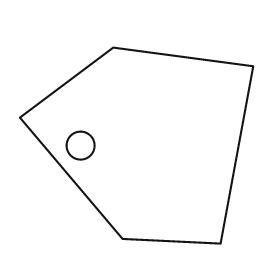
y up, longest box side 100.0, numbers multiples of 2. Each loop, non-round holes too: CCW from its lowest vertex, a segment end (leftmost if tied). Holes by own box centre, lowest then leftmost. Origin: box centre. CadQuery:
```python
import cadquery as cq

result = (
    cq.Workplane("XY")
    .moveTo(36.0, -42.0)
    .lineTo(50.0, 34.0)
    .lineTo(-10.0, 42.0)
    .lineTo(-50.0, 12.0)
    .lineTo(-6.0, -40.0)
    .close()
    .moveTo(-24.0, 0.0)
    .circle(6.0)
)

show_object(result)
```